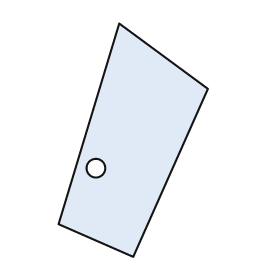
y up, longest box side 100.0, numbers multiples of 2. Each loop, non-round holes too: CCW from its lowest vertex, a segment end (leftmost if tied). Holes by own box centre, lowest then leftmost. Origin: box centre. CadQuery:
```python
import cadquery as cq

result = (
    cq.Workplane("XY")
    .moveTo(0.0, -50.0)
    .lineTo(32.0, 22.0)
    .lineTo(-6.0, 50.0)
    .lineTo(-32.0, -36.0)
    .close()
    .moveTo(-16.0, -12.0)
    .circle(4.0)
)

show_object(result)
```